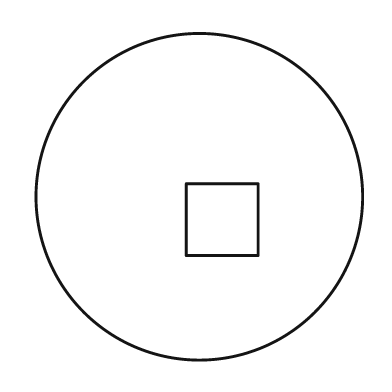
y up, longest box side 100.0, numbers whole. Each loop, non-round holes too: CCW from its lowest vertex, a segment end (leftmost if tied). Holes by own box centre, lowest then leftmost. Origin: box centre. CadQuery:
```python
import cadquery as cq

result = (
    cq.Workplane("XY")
    .moveTo(0.0, 0.0)
    .circle(50.0)
    .moveTo(-4.0, -18.0)
    .lineTo(18.0, -18.0)
    .lineTo(18.0, 4.0)
    .lineTo(-4.0, 4.0)
    .close()
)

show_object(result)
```